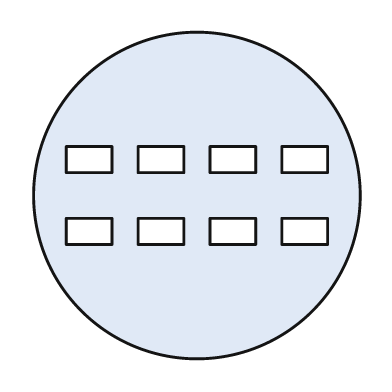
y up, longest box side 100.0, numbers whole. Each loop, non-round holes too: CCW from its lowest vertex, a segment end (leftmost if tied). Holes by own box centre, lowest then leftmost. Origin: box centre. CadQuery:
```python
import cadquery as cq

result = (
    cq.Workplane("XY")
    .moveTo(0.0, 0.0)
    .circle(50.0)
    .moveTo(-40.0, -15.0)
    .lineTo(-26.0, -15.0)
    .lineTo(-26.0, -7.0)
    .lineTo(-40.0, -7.0)
    .close()
    .moveTo(-18.0, -15.0)
    .lineTo(-4.0, -15.0)
    .lineTo(-4.0, -7.0)
    .lineTo(-18.0, -7.0)
    .close()
    .moveTo(4.0, -15.0)
    .lineTo(18.0, -15.0)
    .lineTo(18.0, -7.0)
    .lineTo(4.0, -7.0)
    .close()
    .moveTo(26.0, -15.0)
    .lineTo(40.0, -15.0)
    .lineTo(40.0, -7.0)
    .lineTo(26.0, -7.0)
    .close()
    .moveTo(-40.0, 7.0)
    .lineTo(-26.0, 7.0)
    .lineTo(-26.0, 15.0)
    .lineTo(-40.0, 15.0)
    .close()
    .moveTo(-18.0, 7.0)
    .lineTo(-4.0, 7.0)
    .lineTo(-4.0, 15.0)
    .lineTo(-18.0, 15.0)
    .close()
    .moveTo(4.0, 7.0)
    .lineTo(18.0, 7.0)
    .lineTo(18.0, 15.0)
    .lineTo(4.0, 15.0)
    .close()
    .moveTo(26.0, 7.0)
    .lineTo(40.0, 7.0)
    .lineTo(40.0, 15.0)
    .lineTo(26.0, 15.0)
    .close()
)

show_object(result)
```